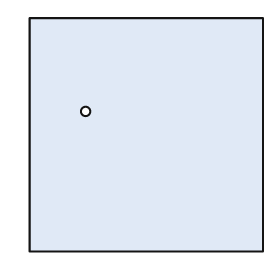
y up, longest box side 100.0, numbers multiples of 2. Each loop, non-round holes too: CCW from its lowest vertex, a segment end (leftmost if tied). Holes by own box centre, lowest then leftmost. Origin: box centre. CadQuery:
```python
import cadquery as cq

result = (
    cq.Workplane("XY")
    .moveTo(-50.0, -50.0)
    .lineTo(50.0, -50.0)
    .lineTo(50.0, 50.0)
    .lineTo(-50.0, 50.0)
    .close()
    .moveTo(-26.0, 10.0)
    .circle(2.0)
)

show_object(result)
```